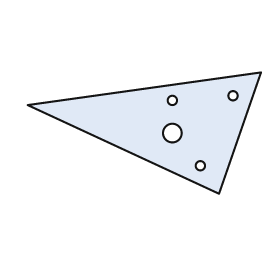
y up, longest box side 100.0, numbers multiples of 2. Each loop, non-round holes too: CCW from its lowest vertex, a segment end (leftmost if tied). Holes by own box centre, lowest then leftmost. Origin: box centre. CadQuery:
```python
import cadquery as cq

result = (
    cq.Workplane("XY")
    .moveTo(32.0, -26.0)
    .lineTo(50.0, 26.0)
    .lineTo(-50.0, 12.0)
    .close()
    .moveTo(24.0, -14.0)
    .circle(2.0)
    .moveTo(12.0, 0.0)
    .circle(4.0)
    .moveTo(12.0, 14.0)
    .circle(2.0)
    .moveTo(38.0, 16.0)
    .circle(2.0)
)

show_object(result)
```